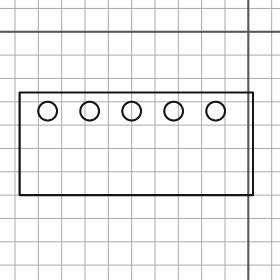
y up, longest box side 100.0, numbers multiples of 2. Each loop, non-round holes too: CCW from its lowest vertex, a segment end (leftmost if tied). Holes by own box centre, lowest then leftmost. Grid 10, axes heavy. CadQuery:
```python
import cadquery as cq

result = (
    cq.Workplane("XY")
    .moveTo(-98.0, -70.0)
    .lineTo(2.0, -70.0)
    .lineTo(2.0, -26.0)
    .lineTo(-98.0, -26.0)
    .close()
    .moveTo(-86.0, -34.0)
    .circle(4.0)
    .moveTo(-68.0, -34.0)
    .circle(4.0)
    .moveTo(-50.0, -34.0)
    .circle(4.0)
    .moveTo(-32.0, -34.0)
    .circle(4.0)
    .moveTo(-14.0, -34.0)
    .circle(4.0)
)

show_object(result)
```